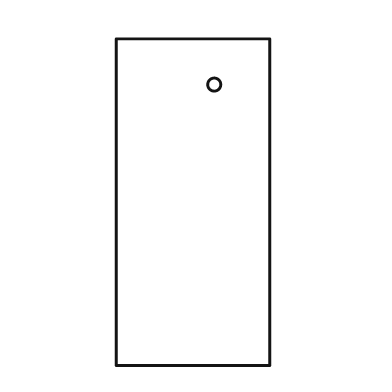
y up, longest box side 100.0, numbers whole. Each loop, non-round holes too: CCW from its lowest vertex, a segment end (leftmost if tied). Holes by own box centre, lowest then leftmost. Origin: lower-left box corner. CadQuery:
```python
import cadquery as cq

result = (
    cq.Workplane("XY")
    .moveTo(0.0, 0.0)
    .lineTo(47.0, 0.0)
    .lineTo(47.0, 100.0)
    .lineTo(0.0, 100.0)
    .close()
    .moveTo(30.0, 86.0)
    .circle(2.0)
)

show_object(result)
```